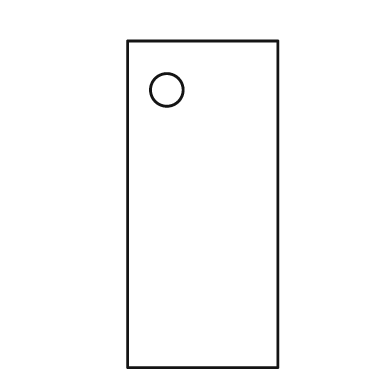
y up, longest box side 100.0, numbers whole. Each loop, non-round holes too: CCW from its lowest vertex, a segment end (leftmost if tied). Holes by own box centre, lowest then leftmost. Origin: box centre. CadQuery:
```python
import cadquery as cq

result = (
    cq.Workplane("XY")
    .moveTo(-23.0, -50.0)
    .lineTo(23.0, -50.0)
    .lineTo(23.0, 50.0)
    .lineTo(-23.0, 50.0)
    .close()
    .moveTo(-11.0, 35.0)
    .circle(5.0)
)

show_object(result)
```